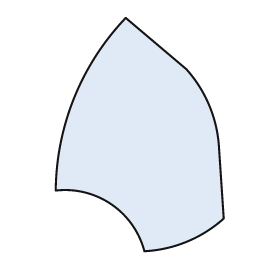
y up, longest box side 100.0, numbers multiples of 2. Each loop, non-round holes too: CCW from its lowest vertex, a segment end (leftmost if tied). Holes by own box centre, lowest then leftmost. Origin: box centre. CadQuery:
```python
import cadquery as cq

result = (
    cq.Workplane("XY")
    .moveTo(2.0, -50.0)
    .threePointArc((20.0, -46.0), (36.0, -36.0))
    .lineTo(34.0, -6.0)
    .threePointArc((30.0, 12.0), (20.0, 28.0))
    .lineTo(-6.0, 50.0)
    .threePointArc((-28.0, 16.0), (-36.0, -24.0))
    .threePointArc((-12.0, -30.0), (2.0, -50.0))
    .close()
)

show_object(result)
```